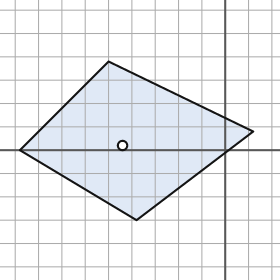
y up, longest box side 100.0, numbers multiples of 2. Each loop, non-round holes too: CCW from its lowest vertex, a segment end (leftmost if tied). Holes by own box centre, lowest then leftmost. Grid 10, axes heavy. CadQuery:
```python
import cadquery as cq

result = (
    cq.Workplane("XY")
    .moveTo(-38.0, -30.0)
    .lineTo(12.0, 8.0)
    .lineTo(-50.0, 38.0)
    .lineTo(-88.0, 0.0)
    .close()
    .moveTo(-44.0, 2.0)
    .circle(2.0)
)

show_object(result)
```